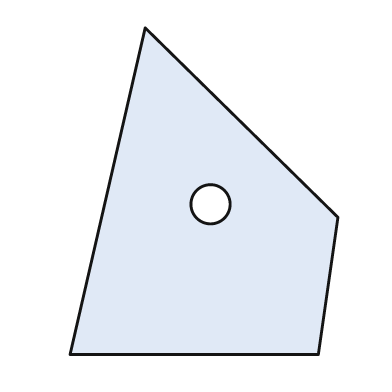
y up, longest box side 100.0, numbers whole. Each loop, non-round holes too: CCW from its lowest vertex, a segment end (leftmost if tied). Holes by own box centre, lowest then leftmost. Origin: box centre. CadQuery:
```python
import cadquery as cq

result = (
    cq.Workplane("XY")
    .moveTo(-41.0, -50.0)
    .lineTo(35.0, -50.0)
    .lineTo(41.0, -8.0)
    .lineTo(-18.0, 50.0)
    .close()
    .moveTo(2.0, -4.0)
    .circle(6.0)
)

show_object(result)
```